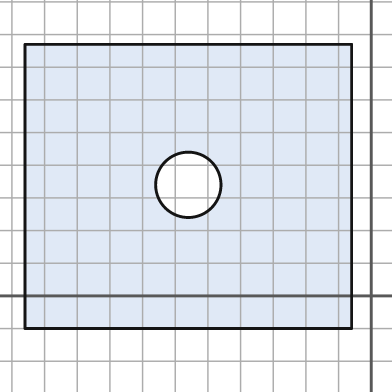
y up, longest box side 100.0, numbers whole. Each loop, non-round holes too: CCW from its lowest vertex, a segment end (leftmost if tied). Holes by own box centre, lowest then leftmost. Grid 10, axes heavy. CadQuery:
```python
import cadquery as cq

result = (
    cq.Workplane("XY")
    .moveTo(-106.0, -10.0)
    .lineTo(-6.0, -10.0)
    .lineTo(-6.0, 77.0)
    .lineTo(-106.0, 77.0)
    .close()
    .moveTo(-56.0, 34.0)
    .circle(10.0)
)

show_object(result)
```